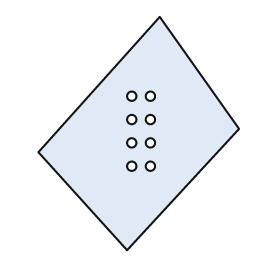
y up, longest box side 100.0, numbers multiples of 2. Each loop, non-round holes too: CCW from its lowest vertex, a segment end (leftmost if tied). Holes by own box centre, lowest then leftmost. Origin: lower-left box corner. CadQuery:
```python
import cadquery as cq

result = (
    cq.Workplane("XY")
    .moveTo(38.0, 0.0)
    .lineTo(86.0, 52.0)
    .lineTo(52.0, 100.0)
    .lineTo(0.0, 42.0)
    .close()
    .moveTo(40.0, 36.0)
    .circle(2.0)
    .moveTo(48.0, 36.0)
    .circle(2.0)
    .moveTo(40.0, 46.0)
    .circle(2.0)
    .moveTo(48.0, 46.0)
    .circle(2.0)
    .moveTo(40.0, 56.0)
    .circle(2.0)
    .moveTo(48.0, 56.0)
    .circle(2.0)
    .moveTo(40.0, 66.0)
    .circle(2.0)
    .moveTo(48.0, 66.0)
    .circle(2.0)
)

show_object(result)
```